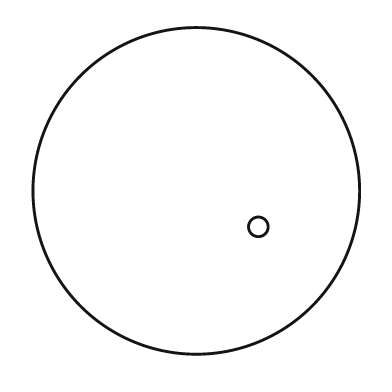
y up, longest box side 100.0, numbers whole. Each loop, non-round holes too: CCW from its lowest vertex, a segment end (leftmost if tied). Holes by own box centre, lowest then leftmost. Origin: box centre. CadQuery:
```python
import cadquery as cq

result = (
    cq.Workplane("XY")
    .moveTo(0.0, 0.0)
    .circle(50.0)
    .moveTo(19.0, -11.0)
    .circle(3.0)
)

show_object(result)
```